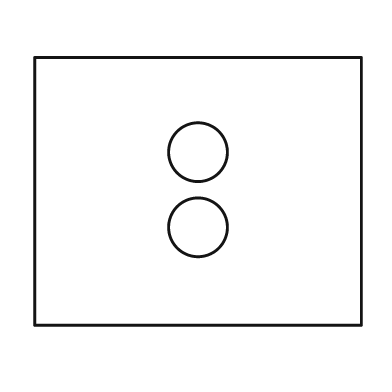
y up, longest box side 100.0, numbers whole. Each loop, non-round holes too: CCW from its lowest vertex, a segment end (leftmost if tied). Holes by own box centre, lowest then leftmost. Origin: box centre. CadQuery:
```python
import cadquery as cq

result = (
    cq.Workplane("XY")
    .moveTo(-50.0, -41.0)
    .lineTo(50.0, -41.0)
    .lineTo(50.0, 41.0)
    .lineTo(-50.0, 41.0)
    .close()
    .moveTo(0.0, -11.0)
    .circle(9.0)
    .moveTo(0.0, 12.0)
    .circle(9.0)
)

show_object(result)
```